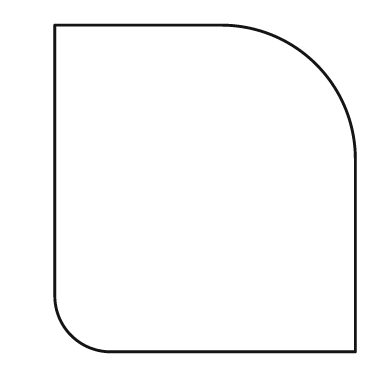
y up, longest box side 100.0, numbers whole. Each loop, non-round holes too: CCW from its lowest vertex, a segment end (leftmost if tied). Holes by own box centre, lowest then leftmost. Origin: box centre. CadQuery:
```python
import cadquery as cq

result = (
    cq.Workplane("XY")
    .moveTo(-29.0, -50.0)
    .lineTo(46.0, -50.0)
    .lineTo(46.0, 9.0)
    .threePointArc((34.0, 38.0), (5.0, 50.0))
    .lineTo(-46.0, 50.0)
    .lineTo(-46.0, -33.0)
    .threePointArc((-41.0, -45.0), (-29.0, -50.0))
    .close()
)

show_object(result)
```